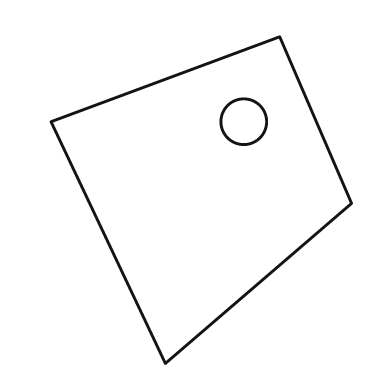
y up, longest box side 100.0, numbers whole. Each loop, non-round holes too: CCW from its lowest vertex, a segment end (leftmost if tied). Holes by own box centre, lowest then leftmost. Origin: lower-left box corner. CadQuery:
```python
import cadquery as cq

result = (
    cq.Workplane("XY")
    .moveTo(35.0, 0.0)
    .lineTo(92.0, 49.0)
    .lineTo(70.0, 100.0)
    .lineTo(0.0, 74.0)
    .close()
    .moveTo(59.0, 74.0)
    .circle(7.0)
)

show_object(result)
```